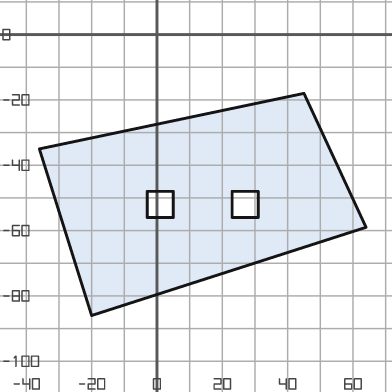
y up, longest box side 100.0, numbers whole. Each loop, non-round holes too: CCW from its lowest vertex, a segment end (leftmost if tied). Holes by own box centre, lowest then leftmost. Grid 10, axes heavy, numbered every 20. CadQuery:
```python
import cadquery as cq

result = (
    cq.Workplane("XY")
    .moveTo(-20.0, -86.0)
    .lineTo(64.0, -59.0)
    .lineTo(45.0, -18.0)
    .lineTo(-36.0, -35.0)
    .close()
    .moveTo(-3.0, -56.0)
    .lineTo(5.0, -56.0)
    .lineTo(5.0, -48.0)
    .lineTo(-3.0, -48.0)
    .close()
    .moveTo(23.0, -56.0)
    .lineTo(31.0, -56.0)
    .lineTo(31.0, -48.0)
    .lineTo(23.0, -48.0)
    .close()
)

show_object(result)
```